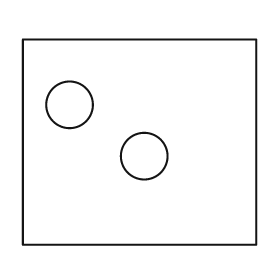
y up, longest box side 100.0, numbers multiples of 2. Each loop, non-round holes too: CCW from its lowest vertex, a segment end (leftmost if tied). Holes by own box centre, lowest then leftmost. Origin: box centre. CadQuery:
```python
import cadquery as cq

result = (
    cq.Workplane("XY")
    .moveTo(-50.0, -44.0)
    .lineTo(50.0, -44.0)
    .lineTo(50.0, 44.0)
    .lineTo(-50.0, 44.0)
    .close()
    .moveTo(2.0, -6.0)
    .circle(10.0)
    .moveTo(-30.0, 16.0)
    .circle(10.0)
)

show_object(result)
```